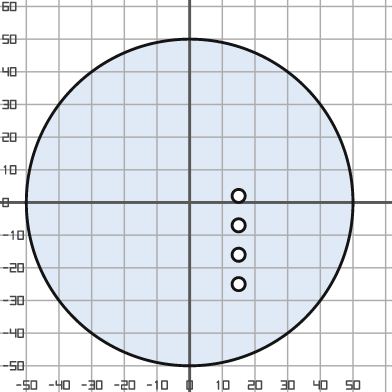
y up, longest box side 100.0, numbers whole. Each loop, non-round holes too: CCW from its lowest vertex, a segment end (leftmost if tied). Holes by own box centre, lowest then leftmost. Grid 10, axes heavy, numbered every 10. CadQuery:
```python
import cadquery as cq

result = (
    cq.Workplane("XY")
    .moveTo(0.0, 0.0)
    .circle(50.0)
    .moveTo(15.0, -25.0)
    .circle(2.0)
    .moveTo(15.0, -16.0)
    .circle(2.0)
    .moveTo(15.0, -7.0)
    .circle(2.0)
    .moveTo(15.0, 2.0)
    .circle(2.0)
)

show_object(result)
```